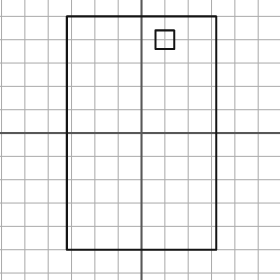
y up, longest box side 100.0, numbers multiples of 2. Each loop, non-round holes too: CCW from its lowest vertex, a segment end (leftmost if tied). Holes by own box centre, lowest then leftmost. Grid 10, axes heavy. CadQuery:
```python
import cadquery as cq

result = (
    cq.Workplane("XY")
    .moveTo(-32.0, -50.0)
    .lineTo(32.0, -50.0)
    .lineTo(32.0, 50.0)
    .lineTo(-32.0, 50.0)
    .close()
    .moveTo(6.0, 36.0)
    .lineTo(14.0, 36.0)
    .lineTo(14.0, 44.0)
    .lineTo(6.0, 44.0)
    .close()
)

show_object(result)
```